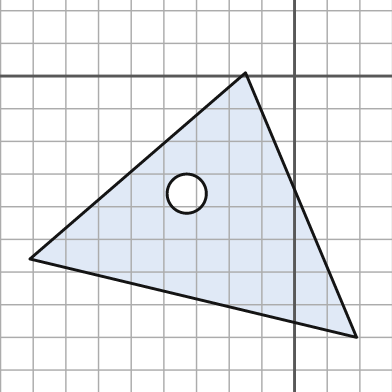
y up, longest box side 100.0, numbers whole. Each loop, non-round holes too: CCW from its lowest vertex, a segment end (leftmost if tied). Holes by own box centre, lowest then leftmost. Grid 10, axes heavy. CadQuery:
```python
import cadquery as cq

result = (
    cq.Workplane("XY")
    .moveTo(19.0, -80.0)
    .lineTo(-15.0, 1.0)
    .lineTo(-81.0, -56.0)
    .close()
    .moveTo(-33.0, -36.0)
    .circle(6.0)
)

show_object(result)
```